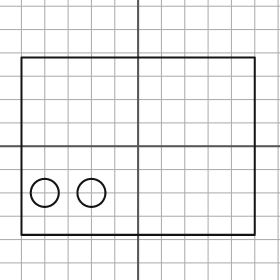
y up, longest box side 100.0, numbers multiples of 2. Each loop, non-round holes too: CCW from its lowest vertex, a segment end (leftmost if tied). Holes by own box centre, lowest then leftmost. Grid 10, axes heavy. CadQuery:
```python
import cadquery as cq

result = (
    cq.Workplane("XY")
    .moveTo(-50.0, -38.0)
    .lineTo(50.0, -38.0)
    .lineTo(50.0, 38.0)
    .lineTo(-50.0, 38.0)
    .close()
    .moveTo(-40.0, -20.0)
    .circle(6.0)
    .moveTo(-20.0, -20.0)
    .circle(6.0)
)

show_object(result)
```